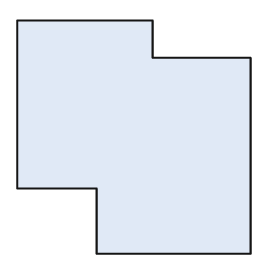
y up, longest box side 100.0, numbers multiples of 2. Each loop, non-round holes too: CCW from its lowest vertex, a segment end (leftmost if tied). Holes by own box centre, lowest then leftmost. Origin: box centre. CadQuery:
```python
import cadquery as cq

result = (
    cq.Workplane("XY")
    .moveTo(-16.0, -50.0)
    .lineTo(50.0, -50.0)
    .lineTo(50.0, 34.0)
    .lineTo(8.0, 34.0)
    .lineTo(8.0, 50.0)
    .lineTo(-50.0, 50.0)
    .lineTo(-50.0, -22.0)
    .lineTo(-16.0, -22.0)
    .close()
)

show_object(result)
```